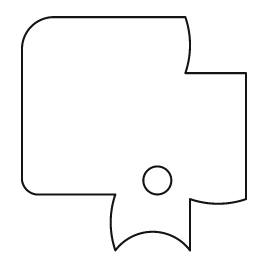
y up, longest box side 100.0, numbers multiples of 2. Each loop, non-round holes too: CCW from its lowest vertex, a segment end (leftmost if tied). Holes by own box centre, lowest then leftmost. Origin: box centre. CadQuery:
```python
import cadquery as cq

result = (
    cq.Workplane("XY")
    .moveTo(-8.0, -50.0)
    .threePointArc((8.0, -42.0), (24.0, -50.0))
    .lineTo(24.0, -28.0)
    .threePointArc((36.0, -30.0), (48.0, -28.0))
    .lineTo(48.0, 26.0)
    .lineTo(22.0, 26.0)
    .threePointArc((24.0, 38.0), (22.0, 50.0))
    .lineTo(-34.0, 50.0)
    .threePointArc((-44.0, 46.0), (-48.0, 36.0))
    .lineTo(-48.0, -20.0)
    .threePointArc((-46.0, -24.0), (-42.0, -26.0))
    .lineTo(-8.0, -26.0)
    .threePointArc((-10.0, -38.0), (-8.0, -50.0))
    .close()
    .moveTo(10.0, -20.0)
    .circle(6.0)
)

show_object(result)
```